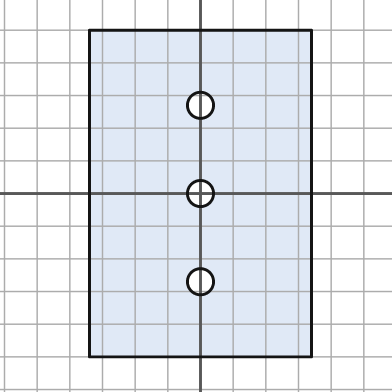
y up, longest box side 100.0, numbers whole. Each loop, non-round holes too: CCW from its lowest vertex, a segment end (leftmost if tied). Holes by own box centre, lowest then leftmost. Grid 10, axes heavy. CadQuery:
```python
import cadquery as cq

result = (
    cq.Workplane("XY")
    .moveTo(-34.0, -50.0)
    .lineTo(34.0, -50.0)
    .lineTo(34.0, 50.0)
    .lineTo(-34.0, 50.0)
    .close()
    .moveTo(0.0, -27.0)
    .circle(4.0)
    .moveTo(0.0, 0.0)
    .circle(4.0)
    .moveTo(0.0, 27.0)
    .circle(4.0)
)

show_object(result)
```